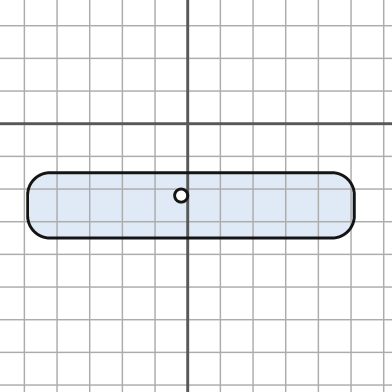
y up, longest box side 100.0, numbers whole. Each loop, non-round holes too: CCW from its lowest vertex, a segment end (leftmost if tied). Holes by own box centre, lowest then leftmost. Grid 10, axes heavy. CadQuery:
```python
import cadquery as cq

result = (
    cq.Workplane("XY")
    .moveTo(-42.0, -35.0)
    .lineTo(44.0, -35.0)
    .threePointArc((49.0, -33.0), (51.0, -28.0))
    .lineTo(51.0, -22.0)
    .threePointArc((49.0, -17.0), (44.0, -15.0))
    .lineTo(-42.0, -15.0)
    .threePointArc((-47.0, -17.0), (-49.0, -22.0))
    .lineTo(-49.0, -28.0)
    .threePointArc((-47.0, -33.0), (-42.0, -35.0))
    .close()
    .moveTo(-2.0, -22.0)
    .circle(2.0)
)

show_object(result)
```